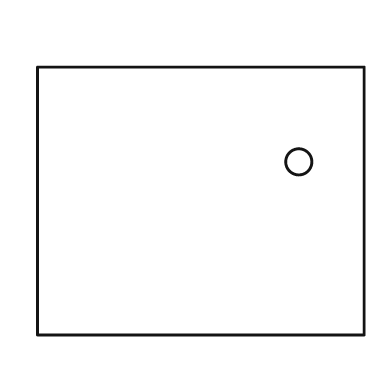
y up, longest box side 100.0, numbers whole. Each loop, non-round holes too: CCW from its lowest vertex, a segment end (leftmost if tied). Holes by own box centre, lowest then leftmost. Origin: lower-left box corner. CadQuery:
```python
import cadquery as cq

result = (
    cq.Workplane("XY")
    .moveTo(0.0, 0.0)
    .lineTo(100.0, 0.0)
    .lineTo(100.0, 82.0)
    .lineTo(0.0, 82.0)
    .close()
    .moveTo(80.0, 53.0)
    .circle(4.0)
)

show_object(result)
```